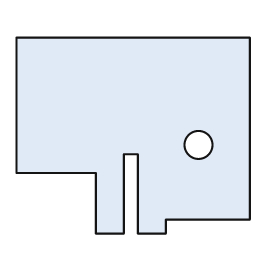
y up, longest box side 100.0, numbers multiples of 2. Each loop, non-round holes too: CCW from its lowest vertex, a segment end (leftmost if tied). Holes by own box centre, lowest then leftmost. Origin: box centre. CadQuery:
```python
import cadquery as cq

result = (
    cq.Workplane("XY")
    .moveTo(-16.0, -42.0)
    .lineTo(-4.0, -42.0)
    .lineTo(-4.0, -8.0)
    .lineTo(2.0, -8.0)
    .lineTo(2.0, -42.0)
    .lineTo(14.0, -42.0)
    .lineTo(14.0, -36.0)
    .lineTo(50.0, -36.0)
    .lineTo(50.0, 42.0)
    .lineTo(-50.0, 42.0)
    .lineTo(-50.0, -16.0)
    .lineTo(-16.0, -16.0)
    .close()
    .moveTo(28.0, -4.0)
    .circle(6.0)
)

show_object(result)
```